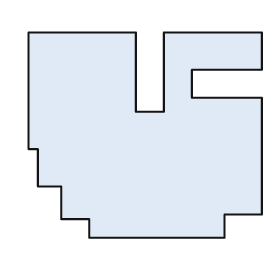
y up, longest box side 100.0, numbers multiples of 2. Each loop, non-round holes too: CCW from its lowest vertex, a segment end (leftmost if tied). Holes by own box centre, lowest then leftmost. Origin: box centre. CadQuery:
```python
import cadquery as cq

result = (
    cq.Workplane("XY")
    .moveTo(-24.0, -44.0)
    .lineTo(34.0, -44.0)
    .lineTo(34.0, -34.0)
    .lineTo(50.0, -34.0)
    .lineTo(50.0, 16.0)
    .lineTo(20.0, 16.0)
    .lineTo(20.0, 28.0)
    .lineTo(50.0, 28.0)
    .lineTo(50.0, 44.0)
    .lineTo(8.0, 44.0)
    .lineTo(8.0, 10.0)
    .lineTo(-4.0, 10.0)
    .lineTo(-4.0, 44.0)
    .lineTo(-50.0, 44.0)
    .lineTo(-50.0, -6.0)
    .lineTo(-46.0, -6.0)
    .lineTo(-46.0, -22.0)
    .lineTo(-36.0, -22.0)
    .lineTo(-36.0, -36.0)
    .lineTo(-24.0, -36.0)
    .close()
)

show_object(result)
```